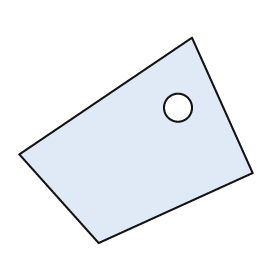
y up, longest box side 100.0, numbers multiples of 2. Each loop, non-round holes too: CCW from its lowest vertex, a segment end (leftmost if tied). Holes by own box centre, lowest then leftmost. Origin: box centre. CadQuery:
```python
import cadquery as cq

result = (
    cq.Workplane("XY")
    .moveTo(-16.0, -44.0)
    .lineTo(50.0, -14.0)
    .lineTo(24.0, 44.0)
    .lineTo(-50.0, -6.0)
    .close()
    .moveTo(18.0, 14.0)
    .circle(6.0)
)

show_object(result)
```